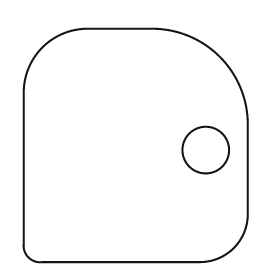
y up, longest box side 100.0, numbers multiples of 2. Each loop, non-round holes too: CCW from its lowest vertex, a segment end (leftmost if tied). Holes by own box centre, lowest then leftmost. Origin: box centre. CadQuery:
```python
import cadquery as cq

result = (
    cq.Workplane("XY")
    .moveTo(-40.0, -50.0)
    .lineTo(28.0, -50.0)
    .threePointArc((42.0, -44.0), (48.0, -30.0))
    .lineTo(48.0, 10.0)
    .threePointArc((36.0, 38.0), (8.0, 50.0))
    .lineTo(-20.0, 50.0)
    .threePointArc((-40.0, 42.0), (-48.0, 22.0))
    .lineTo(-48.0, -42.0)
    .threePointArc((-46.0, -48.0), (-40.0, -50.0))
    .close()
    .moveTo(30.0, -2.0)
    .circle(10.0)
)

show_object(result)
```